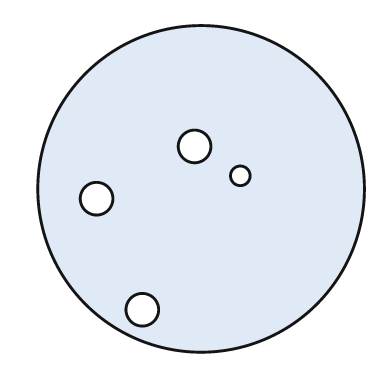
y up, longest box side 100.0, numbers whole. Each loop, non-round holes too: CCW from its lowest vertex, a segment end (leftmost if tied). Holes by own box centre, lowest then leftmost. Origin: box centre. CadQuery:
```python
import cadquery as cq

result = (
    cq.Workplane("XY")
    .moveTo(0.0, 0.0)
    .circle(50.0)
    .moveTo(-18.0, -37.0)
    .circle(5.0)
    .moveTo(-32.0, -3.0)
    .circle(5.0)
    .moveTo(12.0, 4.0)
    .circle(3.0)
    .moveTo(-2.0, 13.0)
    .circle(5.0)
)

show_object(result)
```